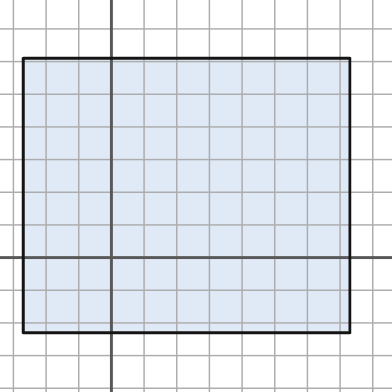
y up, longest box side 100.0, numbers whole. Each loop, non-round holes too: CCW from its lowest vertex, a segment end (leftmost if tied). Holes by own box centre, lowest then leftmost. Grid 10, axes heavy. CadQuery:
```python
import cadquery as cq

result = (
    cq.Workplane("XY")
    .moveTo(-27.0, -23.0)
    .lineTo(73.0, -23.0)
    .lineTo(73.0, 61.0)
    .lineTo(-27.0, 61.0)
    .close()
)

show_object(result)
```